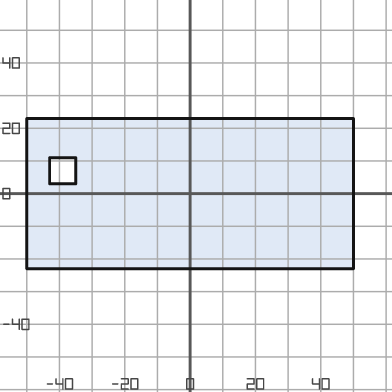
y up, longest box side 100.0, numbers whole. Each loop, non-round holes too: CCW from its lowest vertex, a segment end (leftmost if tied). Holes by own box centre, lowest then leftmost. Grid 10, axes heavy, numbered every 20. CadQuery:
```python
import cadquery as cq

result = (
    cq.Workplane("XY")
    .moveTo(-50.0, -23.0)
    .lineTo(50.0, -23.0)
    .lineTo(50.0, 23.0)
    .lineTo(-50.0, 23.0)
    .close()
    .moveTo(-43.0, 3.0)
    .lineTo(-35.0, 3.0)
    .lineTo(-35.0, 11.0)
    .lineTo(-43.0, 11.0)
    .close()
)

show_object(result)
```